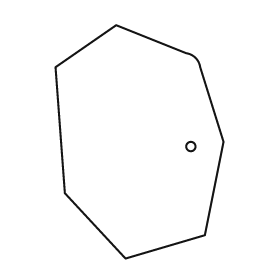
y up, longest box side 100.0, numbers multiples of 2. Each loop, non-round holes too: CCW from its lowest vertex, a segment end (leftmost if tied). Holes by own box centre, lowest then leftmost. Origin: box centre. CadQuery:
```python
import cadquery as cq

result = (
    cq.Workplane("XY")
    .moveTo(-6.0, -50.0)
    .lineTo(28.0, -40.0)
    .lineTo(36.0, 0.0)
    .lineTo(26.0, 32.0)
    .threePointArc((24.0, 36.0), (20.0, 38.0))
    .lineTo(-10.0, 50.0)
    .lineTo(-36.0, 32.0)
    .lineTo(-32.0, -22.0)
    .close()
    .moveTo(22.0, -2.0)
    .circle(2.0)
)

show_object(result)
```